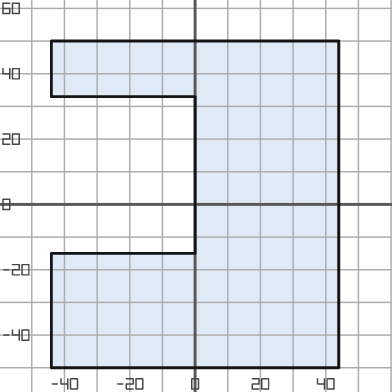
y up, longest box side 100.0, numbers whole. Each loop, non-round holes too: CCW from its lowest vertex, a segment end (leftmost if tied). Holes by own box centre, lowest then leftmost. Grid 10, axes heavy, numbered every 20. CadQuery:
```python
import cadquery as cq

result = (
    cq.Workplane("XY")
    .moveTo(-44.0, -50.0)
    .lineTo(44.0, -50.0)
    .lineTo(44.0, 50.0)
    .lineTo(-44.0, 50.0)
    .lineTo(-44.0, 33.0)
    .lineTo(0.0, 33.0)
    .lineTo(0.0, -15.0)
    .lineTo(-44.0, -15.0)
    .close()
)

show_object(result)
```